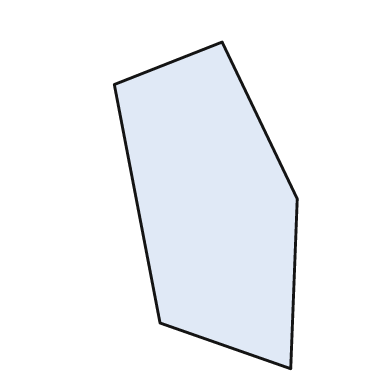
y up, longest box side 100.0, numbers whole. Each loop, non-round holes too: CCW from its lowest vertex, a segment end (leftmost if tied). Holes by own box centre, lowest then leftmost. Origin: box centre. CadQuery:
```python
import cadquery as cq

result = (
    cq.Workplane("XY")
    .moveTo(26.0, -50.0)
    .lineTo(28.0, 2.0)
    .lineTo(5.0, 50.0)
    .lineTo(-28.0, 37.0)
    .lineTo(-14.0, -36.0)
    .close()
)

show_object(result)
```